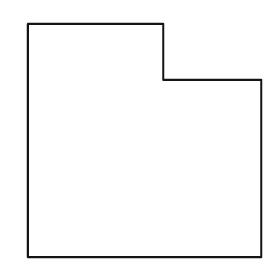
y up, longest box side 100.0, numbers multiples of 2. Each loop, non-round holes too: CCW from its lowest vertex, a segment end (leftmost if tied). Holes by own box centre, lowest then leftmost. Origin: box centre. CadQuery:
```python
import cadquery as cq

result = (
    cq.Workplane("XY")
    .moveTo(-50.0, -50.0)
    .lineTo(50.0, -50.0)
    .lineTo(50.0, 26.0)
    .lineTo(8.0, 26.0)
    .lineTo(8.0, 50.0)
    .lineTo(-50.0, 50.0)
    .close()
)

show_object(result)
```